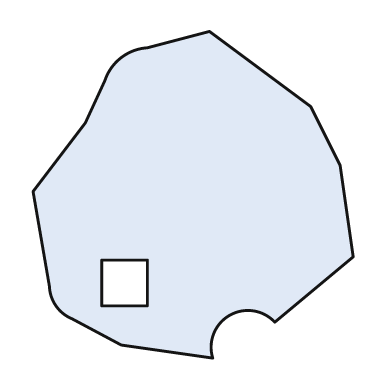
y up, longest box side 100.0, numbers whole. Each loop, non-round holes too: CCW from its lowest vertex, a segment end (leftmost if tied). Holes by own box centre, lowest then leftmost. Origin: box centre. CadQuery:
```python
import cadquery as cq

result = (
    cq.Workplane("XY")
    .moveTo(6.0, -50.0)
    .threePointArc((11.0, -37.0), (25.0, -39.0))
    .lineTo(49.0, -19.0)
    .lineTo(45.0, 9.0)
    .lineTo(36.0, 27.0)
    .lineTo(5.0, 50.0)
    .lineTo(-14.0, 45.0)
    .threePointArc((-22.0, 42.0), (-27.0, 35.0))
    .lineTo(-33.0, 22.0)
    .lineTo(-49.0, 1.0)
    .lineTo(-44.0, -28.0)
    .threePointArc((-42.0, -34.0), (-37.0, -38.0))
    .lineTo(-22.0, -46.0)
    .close()
    .moveTo(-28.0, -34.0)
    .lineTo(-14.0, -34.0)
    .lineTo(-14.0, -20.0)
    .lineTo(-28.0, -20.0)
    .close()
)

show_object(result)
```